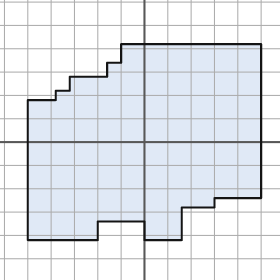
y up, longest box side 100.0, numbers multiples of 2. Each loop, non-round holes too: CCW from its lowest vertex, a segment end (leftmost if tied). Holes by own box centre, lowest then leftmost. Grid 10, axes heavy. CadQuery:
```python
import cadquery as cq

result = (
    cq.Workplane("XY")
    .moveTo(-50.0, -42.0)
    .lineTo(-20.0, -42.0)
    .lineTo(-20.0, -34.0)
    .lineTo(0.0, -34.0)
    .lineTo(0.0, -42.0)
    .lineTo(16.0, -42.0)
    .lineTo(16.0, -28.0)
    .lineTo(30.0, -28.0)
    .lineTo(30.0, -24.0)
    .lineTo(50.0, -24.0)
    .lineTo(50.0, 42.0)
    .lineTo(-10.0, 42.0)
    .lineTo(-10.0, 34.0)
    .lineTo(-16.0, 34.0)
    .lineTo(-16.0, 28.0)
    .lineTo(-32.0, 28.0)
    .lineTo(-32.0, 22.0)
    .lineTo(-38.0, 22.0)
    .lineTo(-38.0, 18.0)
    .lineTo(-50.0, 18.0)
    .close()
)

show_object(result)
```